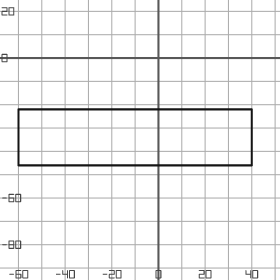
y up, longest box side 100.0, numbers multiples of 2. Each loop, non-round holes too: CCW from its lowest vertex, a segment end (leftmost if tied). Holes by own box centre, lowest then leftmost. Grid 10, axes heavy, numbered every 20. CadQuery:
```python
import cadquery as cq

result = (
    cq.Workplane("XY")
    .moveTo(-60.0, -46.0)
    .lineTo(40.0, -46.0)
    .lineTo(40.0, -22.0)
    .lineTo(-60.0, -22.0)
    .close()
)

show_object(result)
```